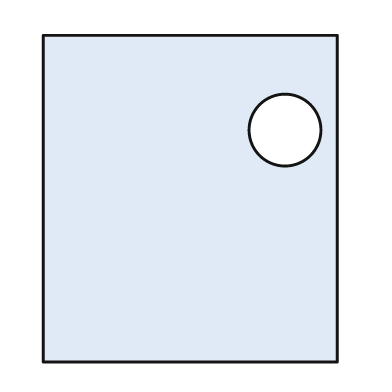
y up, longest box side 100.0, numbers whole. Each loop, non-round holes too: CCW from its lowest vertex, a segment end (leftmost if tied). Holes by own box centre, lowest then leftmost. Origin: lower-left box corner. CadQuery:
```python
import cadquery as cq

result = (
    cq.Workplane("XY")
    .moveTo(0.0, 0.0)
    .lineTo(90.0, 0.0)
    .lineTo(90.0, 100.0)
    .lineTo(0.0, 100.0)
    .close()
    .moveTo(74.0, 71.0)
    .circle(11.0)
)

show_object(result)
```